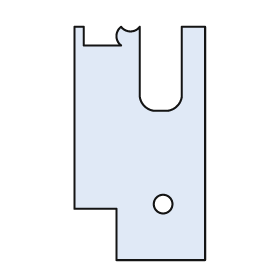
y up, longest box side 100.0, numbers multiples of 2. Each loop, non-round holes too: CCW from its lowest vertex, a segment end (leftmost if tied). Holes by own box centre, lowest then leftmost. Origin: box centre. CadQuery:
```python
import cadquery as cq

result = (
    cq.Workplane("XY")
    .moveTo(-10.0, -50.0)
    .lineTo(28.0, -50.0)
    .lineTo(28.0, 50.0)
    .lineTo(18.0, 50.0)
    .lineTo(18.0, 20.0)
    .threePointArc((16.0, 16.0), (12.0, 14.0))
    .lineTo(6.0, 14.0)
    .threePointArc((2.0, 16.0), (0.0, 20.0))
    .lineTo(0.0, 50.0)
    .threePointArc((-4.0, 48.0), (-8.0, 50.0))
    .threePointArc((-10.0, 46.0), (-8.0, 42.0))
    .lineTo(-24.0, 42.0)
    .lineTo(-24.0, 50.0)
    .lineTo(-28.0, 50.0)
    .lineTo(-28.0, -28.0)
    .lineTo(-10.0, -28.0)
    .close()
    .moveTo(10.0, -26.0)
    .circle(4.0)
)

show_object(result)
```